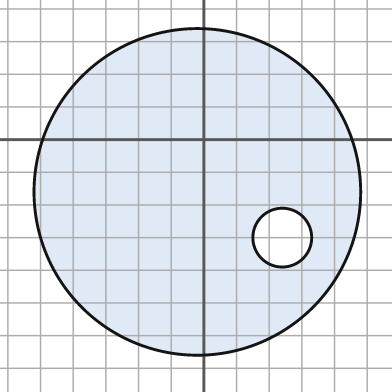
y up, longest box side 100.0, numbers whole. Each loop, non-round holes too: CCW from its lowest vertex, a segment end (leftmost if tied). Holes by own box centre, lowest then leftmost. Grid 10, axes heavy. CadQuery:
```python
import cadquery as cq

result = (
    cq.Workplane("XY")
    .moveTo(-2.0, -16.0)
    .circle(50.0)
    .moveTo(24.0, -30.0)
    .circle(9.0)
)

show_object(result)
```